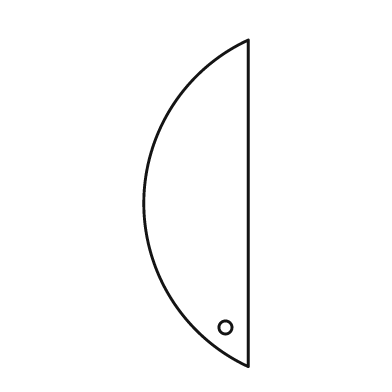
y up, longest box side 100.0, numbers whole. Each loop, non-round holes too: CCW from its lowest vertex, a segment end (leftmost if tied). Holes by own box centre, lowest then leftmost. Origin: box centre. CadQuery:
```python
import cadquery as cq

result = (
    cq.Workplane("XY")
    .moveTo(16.0, -50.0)
    .lineTo(16.0, 50.0)
    .threePointArc((-16.0, 0.0), (16.0, -50.0))
    .close()
    .moveTo(9.0, -38.0)
    .circle(2.0)
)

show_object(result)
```